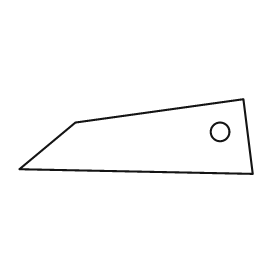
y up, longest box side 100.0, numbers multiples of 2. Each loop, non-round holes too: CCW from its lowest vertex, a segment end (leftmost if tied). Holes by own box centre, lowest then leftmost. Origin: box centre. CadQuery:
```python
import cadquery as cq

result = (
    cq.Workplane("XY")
    .moveTo(50.0, -16.0)
    .lineTo(46.0, 16.0)
    .lineTo(-26.0, 6.0)
    .lineTo(-50.0, -14.0)
    .close()
    .moveTo(36.0, 2.0)
    .circle(4.0)
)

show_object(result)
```